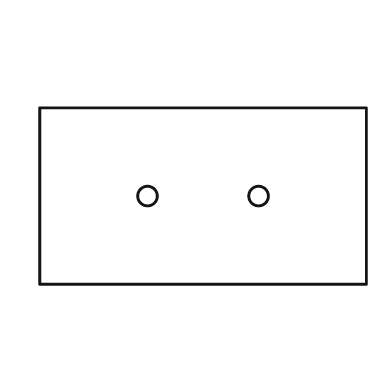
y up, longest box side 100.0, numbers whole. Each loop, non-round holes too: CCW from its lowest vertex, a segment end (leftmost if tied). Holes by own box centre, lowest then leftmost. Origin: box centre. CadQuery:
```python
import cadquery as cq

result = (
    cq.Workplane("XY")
    .moveTo(-50.0, -27.0)
    .lineTo(50.0, -27.0)
    .lineTo(50.0, 27.0)
    .lineTo(-50.0, 27.0)
    .close()
    .moveTo(-17.0, 0.0)
    .circle(3.0)
    .moveTo(17.0, 0.0)
    .circle(3.0)
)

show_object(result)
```